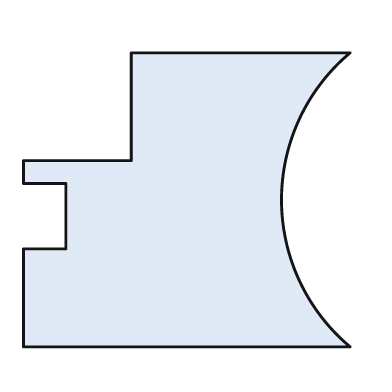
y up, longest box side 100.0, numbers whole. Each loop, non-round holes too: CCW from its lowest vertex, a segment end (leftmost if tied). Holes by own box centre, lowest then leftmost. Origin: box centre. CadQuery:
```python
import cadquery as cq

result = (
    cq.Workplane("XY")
    .moveTo(-50.0, -45.0)
    .lineTo(50.0, -45.0)
    .threePointArc((29.0, 0.0), (50.0, 45.0))
    .lineTo(-17.0, 45.0)
    .lineTo(-17.0, 12.0)
    .lineTo(-50.0, 12.0)
    .lineTo(-50.0, 5.0)
    .lineTo(-37.0, 5.0)
    .lineTo(-37.0, -15.0)
    .lineTo(-50.0, -15.0)
    .close()
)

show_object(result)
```